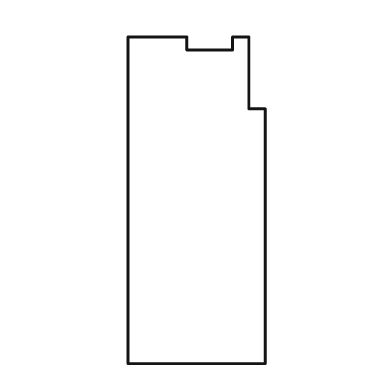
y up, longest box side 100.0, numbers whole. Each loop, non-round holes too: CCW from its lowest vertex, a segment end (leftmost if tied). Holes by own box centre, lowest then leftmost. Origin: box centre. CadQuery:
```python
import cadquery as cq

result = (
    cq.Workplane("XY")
    .moveTo(-21.0, -50.0)
    .lineTo(21.0, -50.0)
    .lineTo(21.0, 28.0)
    .lineTo(16.0, 28.0)
    .lineTo(16.0, 50.0)
    .lineTo(11.0, 50.0)
    .lineTo(11.0, 46.0)
    .lineTo(-3.0, 46.0)
    .lineTo(-3.0, 50.0)
    .lineTo(-21.0, 50.0)
    .close()
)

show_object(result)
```